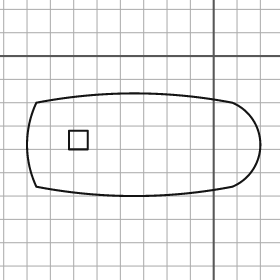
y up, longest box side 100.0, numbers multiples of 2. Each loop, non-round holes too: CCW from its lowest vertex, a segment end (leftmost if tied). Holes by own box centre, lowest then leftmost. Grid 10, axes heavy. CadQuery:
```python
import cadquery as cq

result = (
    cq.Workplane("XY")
    .moveTo(-76.0, -56.0)
    .threePointArc((-34.0, -60.0), (8.0, -56.0))
    .threePointArc((20.0, -38.0), (8.0, -20.0))
    .threePointArc((-34.0, -16.0), (-76.0, -20.0))
    .threePointArc((-80.0, -38.0), (-76.0, -56.0))
    .close()
    .moveTo(-62.0, -40.0)
    .lineTo(-54.0, -40.0)
    .lineTo(-54.0, -32.0)
    .lineTo(-62.0, -32.0)
    .close()
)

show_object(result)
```